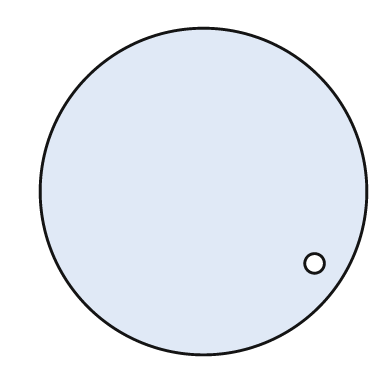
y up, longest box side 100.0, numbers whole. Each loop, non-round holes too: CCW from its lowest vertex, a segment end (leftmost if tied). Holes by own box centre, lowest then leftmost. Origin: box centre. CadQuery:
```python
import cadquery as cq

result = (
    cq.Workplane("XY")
    .moveTo(0.0, 0.0)
    .circle(50.0)
    .moveTo(34.0, -22.0)
    .circle(3.0)
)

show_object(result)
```